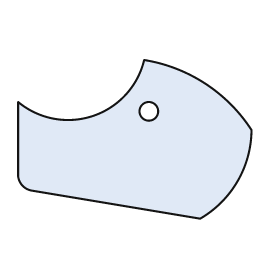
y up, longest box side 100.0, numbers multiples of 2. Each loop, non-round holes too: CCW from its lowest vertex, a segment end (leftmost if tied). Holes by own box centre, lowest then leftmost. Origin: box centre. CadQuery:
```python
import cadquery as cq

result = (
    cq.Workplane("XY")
    .moveTo(28.0, -34.0)
    .threePointArc((44.0, -18.0), (50.0, 4.0))
    .threePointArc((30.0, 24.0), (4.0, 34.0))
    .threePointArc((-18.0, 10.0), (-50.0, 16.0))
    .lineTo(-50.0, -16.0)
    .threePointArc((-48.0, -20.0), (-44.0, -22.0))
    .close()
    .moveTo(6.0, 12.0)
    .circle(4.0)
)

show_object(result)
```